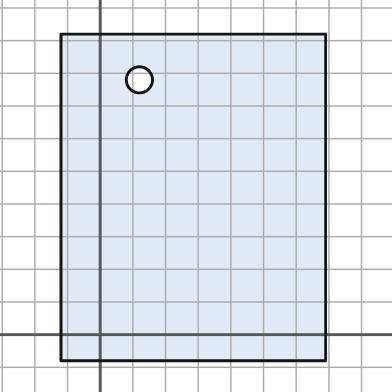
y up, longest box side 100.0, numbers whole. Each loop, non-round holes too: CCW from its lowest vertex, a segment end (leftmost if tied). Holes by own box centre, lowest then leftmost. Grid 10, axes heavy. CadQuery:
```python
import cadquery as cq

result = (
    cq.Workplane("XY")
    .moveTo(-12.0, -8.0)
    .lineTo(69.0, -8.0)
    .lineTo(69.0, 92.0)
    .lineTo(-12.0, 92.0)
    .close()
    .moveTo(12.0, 78.0)
    .circle(4.0)
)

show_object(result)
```